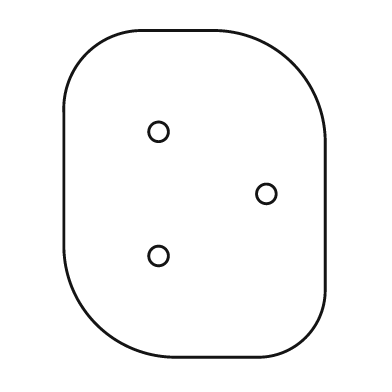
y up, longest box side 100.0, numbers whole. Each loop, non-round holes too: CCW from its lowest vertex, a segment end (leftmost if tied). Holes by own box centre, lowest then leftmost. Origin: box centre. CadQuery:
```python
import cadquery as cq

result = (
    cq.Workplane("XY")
    .moveTo(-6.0, -50.0)
    .lineTo(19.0, -50.0)
    .threePointArc((34.0, -44.0), (40.0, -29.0))
    .lineTo(40.0, 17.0)
    .threePointArc((30.0, 40.0), (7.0, 50.0))
    .lineTo(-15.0, 50.0)
    .threePointArc((-33.0, 43.0), (-40.0, 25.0))
    .lineTo(-40.0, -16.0)
    .threePointArc((-30.0, -40.0), (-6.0, -50.0))
    .close()
    .moveTo(-11.0, -19.0)
    .circle(3.0)
    .moveTo(22.0, 0.0)
    .circle(3.0)
    .moveTo(-11.0, 19.0)
    .circle(3.0)
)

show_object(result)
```